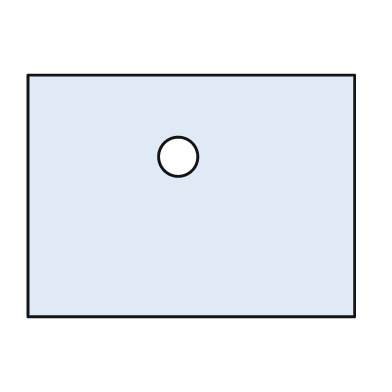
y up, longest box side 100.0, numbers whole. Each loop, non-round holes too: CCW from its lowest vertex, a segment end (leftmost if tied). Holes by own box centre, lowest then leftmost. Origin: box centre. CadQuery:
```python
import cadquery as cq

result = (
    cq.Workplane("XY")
    .moveTo(-50.0, -37.0)
    .lineTo(50.0, -37.0)
    .lineTo(50.0, 37.0)
    .lineTo(-50.0, 37.0)
    .close()
    .moveTo(-4.0, 12.0)
    .circle(6.0)
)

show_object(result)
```